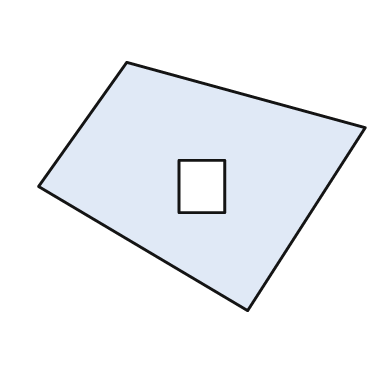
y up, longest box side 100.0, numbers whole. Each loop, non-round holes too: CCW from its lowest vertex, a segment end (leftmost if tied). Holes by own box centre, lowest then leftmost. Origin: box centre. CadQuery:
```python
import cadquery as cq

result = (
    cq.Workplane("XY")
    .moveTo(14.0, -38.0)
    .lineTo(50.0, 18.0)
    .lineTo(-23.0, 38.0)
    .lineTo(-50.0, 0.0)
    .close()
    .moveTo(-7.0, -8.0)
    .lineTo(7.0, -8.0)
    .lineTo(7.0, 8.0)
    .lineTo(-7.0, 8.0)
    .close()
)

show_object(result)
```